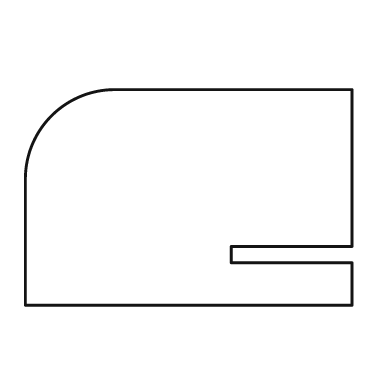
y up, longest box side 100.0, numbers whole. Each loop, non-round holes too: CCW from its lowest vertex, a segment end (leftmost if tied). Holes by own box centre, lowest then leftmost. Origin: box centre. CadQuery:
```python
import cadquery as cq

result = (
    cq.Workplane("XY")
    .moveTo(-50.0, -33.0)
    .lineTo(50.0, -33.0)
    .lineTo(50.0, -20.0)
    .lineTo(13.0, -20.0)
    .lineTo(13.0, -15.0)
    .lineTo(50.0, -15.0)
    .lineTo(50.0, 33.0)
    .lineTo(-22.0, 33.0)
    .threePointArc((-42.0, 25.0), (-50.0, 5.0))
    .close()
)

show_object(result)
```